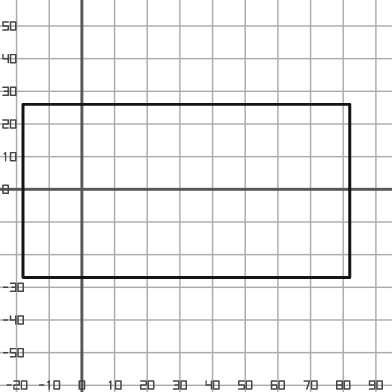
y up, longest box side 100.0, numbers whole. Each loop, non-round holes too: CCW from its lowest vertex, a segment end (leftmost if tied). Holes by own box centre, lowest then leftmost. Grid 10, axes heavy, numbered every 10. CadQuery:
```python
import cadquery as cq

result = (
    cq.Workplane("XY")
    .moveTo(-18.0, -27.0)
    .lineTo(82.0, -27.0)
    .lineTo(82.0, 26.0)
    .lineTo(-18.0, 26.0)
    .close()
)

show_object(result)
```